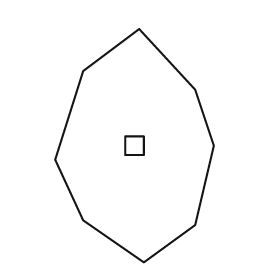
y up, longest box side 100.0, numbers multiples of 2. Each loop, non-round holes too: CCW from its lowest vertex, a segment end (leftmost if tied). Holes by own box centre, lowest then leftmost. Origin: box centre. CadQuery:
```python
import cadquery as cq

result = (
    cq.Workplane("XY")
    .moveTo(4.0, -50.0)
    .lineTo(26.0, -34.0)
    .lineTo(34.0, 0.0)
    .lineTo(26.0, 24.0)
    .lineTo(2.0, 50.0)
    .lineTo(-22.0, 32.0)
    .lineTo(-34.0, -6.0)
    .lineTo(-22.0, -32.0)
    .close()
    .moveTo(-4.0, -4.0)
    .lineTo(4.0, -4.0)
    .lineTo(4.0, 4.0)
    .lineTo(-4.0, 4.0)
    .close()
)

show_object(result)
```